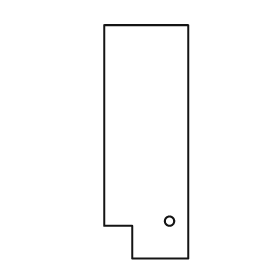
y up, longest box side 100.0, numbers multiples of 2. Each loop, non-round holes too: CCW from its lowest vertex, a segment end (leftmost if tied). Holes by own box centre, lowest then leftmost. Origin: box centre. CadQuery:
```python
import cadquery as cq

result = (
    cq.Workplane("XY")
    .moveTo(-6.0, -50.0)
    .lineTo(18.0, -50.0)
    .lineTo(18.0, 50.0)
    .lineTo(-18.0, 50.0)
    .lineTo(-18.0, -36.0)
    .lineTo(-6.0, -36.0)
    .close()
    .moveTo(10.0, -34.0)
    .circle(2.0)
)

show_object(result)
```